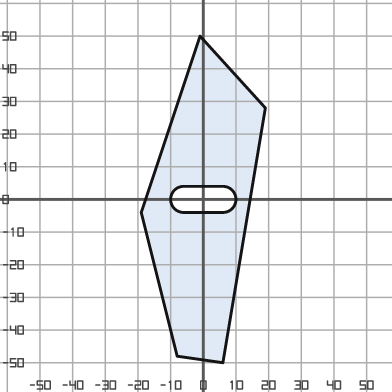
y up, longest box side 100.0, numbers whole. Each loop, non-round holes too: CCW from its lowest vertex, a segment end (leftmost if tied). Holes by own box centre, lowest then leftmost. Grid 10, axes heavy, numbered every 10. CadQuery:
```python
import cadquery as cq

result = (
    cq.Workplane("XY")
    .moveTo(6.0, -50.0)
    .lineTo(19.0, 28.0)
    .lineTo(-1.0, 50.0)
    .lineTo(-19.0, -4.0)
    .lineTo(-8.0, -48.0)
    .close()
    .moveTo(-6.0, -4.0)
    .lineTo(6.0, -4.0)
    .threePointArc((10.0, 0.0), (6.0, 4.0))
    .lineTo(-6.0, 4.0)
    .threePointArc((-10.0, 0.0), (-6.0, -4.0))
    .close()
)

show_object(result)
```